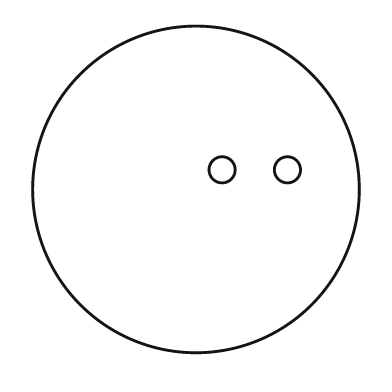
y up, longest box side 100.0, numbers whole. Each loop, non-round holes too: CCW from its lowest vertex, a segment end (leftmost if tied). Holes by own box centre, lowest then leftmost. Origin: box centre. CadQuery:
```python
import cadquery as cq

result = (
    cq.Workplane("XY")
    .moveTo(0.0, 0.0)
    .circle(50.0)
    .moveTo(8.0, 6.0)
    .circle(4.0)
    .moveTo(28.0, 6.0)
    .circle(4.0)
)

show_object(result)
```